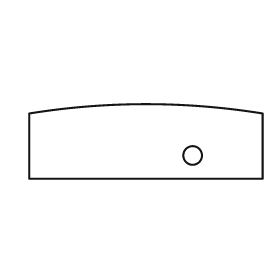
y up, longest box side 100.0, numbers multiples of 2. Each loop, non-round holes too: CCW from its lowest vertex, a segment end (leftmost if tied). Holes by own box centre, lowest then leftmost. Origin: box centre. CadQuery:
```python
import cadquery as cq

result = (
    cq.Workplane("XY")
    .moveTo(-50.0, -16.0)
    .lineTo(50.0, -16.0)
    .lineTo(50.0, 12.0)
    .threePointArc((0.0, 16.0), (-50.0, 12.0))
    .close()
    .moveTo(20.0, -6.0)
    .circle(4.0)
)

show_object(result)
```